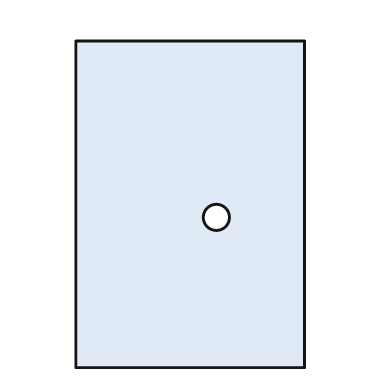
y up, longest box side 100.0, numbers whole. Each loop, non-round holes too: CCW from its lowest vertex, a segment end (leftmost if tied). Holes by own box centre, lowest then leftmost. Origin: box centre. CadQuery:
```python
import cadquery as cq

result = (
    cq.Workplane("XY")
    .moveTo(-35.0, -50.0)
    .lineTo(35.0, -50.0)
    .lineTo(35.0, 50.0)
    .lineTo(-35.0, 50.0)
    .close()
    .moveTo(8.0, -4.0)
    .circle(4.0)
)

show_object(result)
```